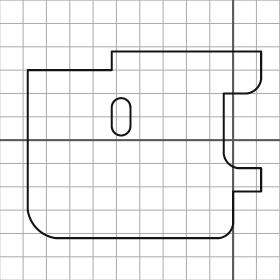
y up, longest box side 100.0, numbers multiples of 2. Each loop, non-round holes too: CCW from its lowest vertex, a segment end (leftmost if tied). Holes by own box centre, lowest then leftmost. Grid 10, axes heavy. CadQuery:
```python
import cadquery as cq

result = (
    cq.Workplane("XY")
    .moveTo(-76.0, -42.0)
    .lineTo(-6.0, -42.0)
    .threePointArc((-2.0, -40.0), (0.0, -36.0))
    .lineTo(0.0, -22.0)
    .lineTo(12.0, -22.0)
    .lineTo(12.0, -12.0)
    .lineTo(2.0, -12.0)
    .threePointArc((-2.0, -10.0), (-4.0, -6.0))
    .lineTo(-4.0, 20.0)
    .lineTo(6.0, 20.0)
    .threePointArc((10.0, 22.0), (12.0, 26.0))
    .lineTo(12.0, 38.0)
    .lineTo(-52.0, 38.0)
    .lineTo(-52.0, 30.0)
    .lineTo(-88.0, 30.0)
    .lineTo(-88.0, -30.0)
    .threePointArc((-84.0, -38.0), (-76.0, -42.0))
    .close()
    .moveTo(-52.0, 6.0)
    .threePointArc((-48.0, 2.0), (-44.0, 6.0))
    .lineTo(-44.0, 14.0)
    .threePointArc((-48.0, 18.0), (-52.0, 14.0))
    .close()
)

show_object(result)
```